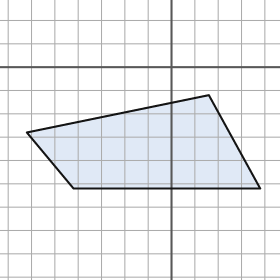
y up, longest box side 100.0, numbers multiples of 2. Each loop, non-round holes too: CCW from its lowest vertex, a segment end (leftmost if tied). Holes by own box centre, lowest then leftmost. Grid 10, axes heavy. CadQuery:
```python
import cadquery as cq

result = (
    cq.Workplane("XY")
    .moveTo(-42.0, -52.0)
    .lineTo(38.0, -52.0)
    .lineTo(16.0, -12.0)
    .lineTo(-62.0, -28.0)
    .close()
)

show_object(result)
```